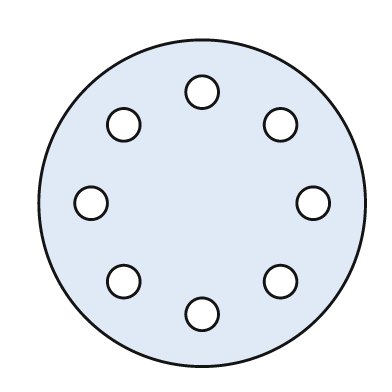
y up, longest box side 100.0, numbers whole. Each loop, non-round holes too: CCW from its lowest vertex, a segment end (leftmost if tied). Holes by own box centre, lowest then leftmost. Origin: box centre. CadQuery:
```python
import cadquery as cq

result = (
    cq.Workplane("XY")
    .moveTo(0.0, 0.0)
    .circle(50.0)
    .moveTo(0.0, -34.0)
    .circle(5.0)
    .moveTo(-24.0, -24.0)
    .circle(5.0)
    .moveTo(24.0, -24.0)
    .circle(5.0)
    .moveTo(-34.0, 0.0)
    .circle(5.0)
    .moveTo(34.0, 0.0)
    .circle(5.0)
    .moveTo(-24.0, 24.0)
    .circle(5.0)
    .moveTo(24.0, 24.0)
    .circle(5.0)
    .moveTo(0.0, 34.0)
    .circle(5.0)
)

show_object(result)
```